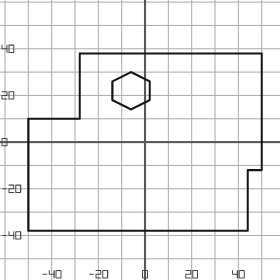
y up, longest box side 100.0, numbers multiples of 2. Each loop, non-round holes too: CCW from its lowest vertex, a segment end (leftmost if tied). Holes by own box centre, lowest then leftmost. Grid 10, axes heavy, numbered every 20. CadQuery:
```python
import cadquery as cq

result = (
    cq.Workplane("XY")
    .moveTo(-50.0, -38.0)
    .lineTo(44.0, -38.0)
    .lineTo(44.0, -12.0)
    .lineTo(50.0, -12.0)
    .lineTo(50.0, 38.0)
    .lineTo(-28.0, 38.0)
    .lineTo(-28.0, 10.0)
    .lineTo(-50.0, 10.0)
    .close()
    .moveTo(-6.0, 14.0)
    .lineTo(2.0, 18.0)
    .lineTo(2.0, 26.0)
    .lineTo(-6.0, 30.0)
    .lineTo(-14.0, 26.0)
    .lineTo(-14.0, 18.0)
    .close()
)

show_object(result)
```